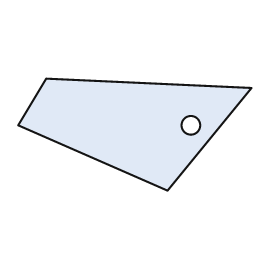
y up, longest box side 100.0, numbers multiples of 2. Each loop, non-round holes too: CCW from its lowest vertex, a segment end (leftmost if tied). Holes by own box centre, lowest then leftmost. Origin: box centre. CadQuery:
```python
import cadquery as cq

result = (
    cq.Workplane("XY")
    .moveTo(14.0, -24.0)
    .lineTo(50.0, 20.0)
    .lineTo(-38.0, 24.0)
    .lineTo(-50.0, 4.0)
    .close()
    .moveTo(24.0, 4.0)
    .circle(4.0)
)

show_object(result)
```